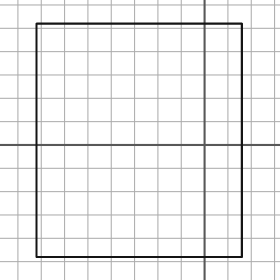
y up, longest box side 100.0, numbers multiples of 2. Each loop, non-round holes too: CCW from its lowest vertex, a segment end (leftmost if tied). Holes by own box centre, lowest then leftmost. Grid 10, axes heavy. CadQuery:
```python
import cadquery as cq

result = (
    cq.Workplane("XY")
    .moveTo(-72.0, -48.0)
    .lineTo(16.0, -48.0)
    .lineTo(16.0, 52.0)
    .lineTo(-72.0, 52.0)
    .close()
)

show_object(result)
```